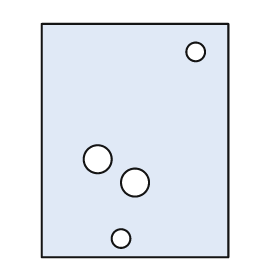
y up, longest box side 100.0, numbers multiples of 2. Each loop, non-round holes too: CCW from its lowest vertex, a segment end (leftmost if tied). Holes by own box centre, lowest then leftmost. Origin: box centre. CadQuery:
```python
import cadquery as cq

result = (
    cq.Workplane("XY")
    .moveTo(-40.0, -50.0)
    .lineTo(40.0, -50.0)
    .lineTo(40.0, 50.0)
    .lineTo(-40.0, 50.0)
    .close()
    .moveTo(-6.0, -42.0)
    .circle(4.0)
    .moveTo(0.0, -18.0)
    .circle(6.0)
    .moveTo(-16.0, -8.0)
    .circle(6.0)
    .moveTo(26.0, 38.0)
    .circle(4.0)
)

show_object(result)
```